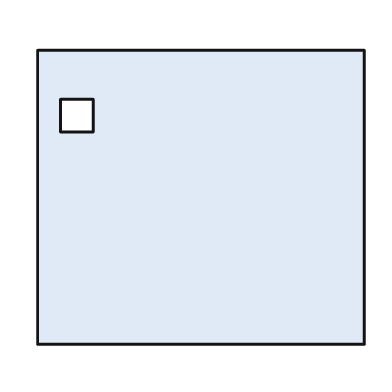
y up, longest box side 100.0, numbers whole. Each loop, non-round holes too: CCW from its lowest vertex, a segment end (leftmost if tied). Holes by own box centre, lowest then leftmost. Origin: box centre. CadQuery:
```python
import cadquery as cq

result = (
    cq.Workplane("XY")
    .moveTo(-50.0, -45.0)
    .lineTo(50.0, -45.0)
    .lineTo(50.0, 45.0)
    .lineTo(-50.0, 45.0)
    .close()
    .moveTo(-43.0, 20.0)
    .lineTo(-33.0, 20.0)
    .lineTo(-33.0, 30.0)
    .lineTo(-43.0, 30.0)
    .close()
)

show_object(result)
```